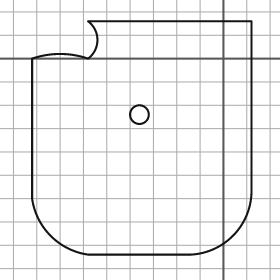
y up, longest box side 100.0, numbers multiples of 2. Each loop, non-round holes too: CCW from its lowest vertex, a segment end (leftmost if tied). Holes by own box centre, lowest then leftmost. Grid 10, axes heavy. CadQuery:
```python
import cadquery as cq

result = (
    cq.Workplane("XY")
    .moveTo(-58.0, -84.0)
    .lineTo(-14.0, -84.0)
    .threePointArc((4.0, -76.0), (12.0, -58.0))
    .lineTo(12.0, 16.0)
    .lineTo(-58.0, 16.0)
    .threePointArc((-54.0, 8.0), (-58.0, 0.0))
    .threePointArc((-70.0, 2.0), (-82.0, 0.0))
    .lineTo(-82.0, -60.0)
    .threePointArc((-74.0, -76.0), (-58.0, -84.0))
    .close()
    .moveTo(-36.0, -24.0)
    .circle(4.0)
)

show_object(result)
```